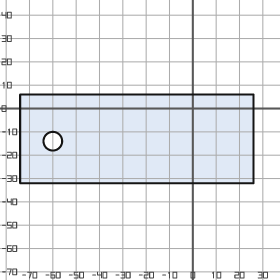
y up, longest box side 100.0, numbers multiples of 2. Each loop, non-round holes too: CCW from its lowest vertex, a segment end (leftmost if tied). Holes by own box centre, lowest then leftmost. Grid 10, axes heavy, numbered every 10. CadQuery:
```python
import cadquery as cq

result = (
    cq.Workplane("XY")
    .moveTo(-74.0, -32.0)
    .lineTo(26.0, -32.0)
    .lineTo(26.0, 6.0)
    .lineTo(-74.0, 6.0)
    .close()
    .moveTo(-60.0, -14.0)
    .circle(4.0)
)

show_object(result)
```